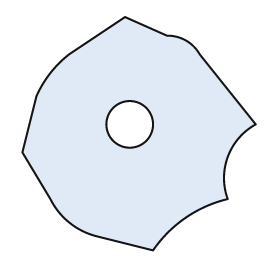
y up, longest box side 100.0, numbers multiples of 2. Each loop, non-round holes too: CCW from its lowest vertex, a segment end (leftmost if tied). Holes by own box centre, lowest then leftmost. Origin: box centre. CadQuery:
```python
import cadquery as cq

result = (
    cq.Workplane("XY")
    .moveTo(6.0, -50.0)
    .threePointArc((20.0, -36.0), (38.0, -28.0))
    .threePointArc((38.0, -10.0), (50.0, 4.0))
    .lineTo(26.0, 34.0)
    .threePointArc((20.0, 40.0), (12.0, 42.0))
    .lineTo(-6.0, 50.0)
    .lineTo(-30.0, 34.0)
    .threePointArc((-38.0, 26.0), (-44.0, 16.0))
    .lineTo(-50.0, -8.0)
    .lineTo(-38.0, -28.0)
    .threePointArc((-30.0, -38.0), (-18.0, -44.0))
    .close()
    .moveTo(-4.0, 4.0)
    .circle(10.0)
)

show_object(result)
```